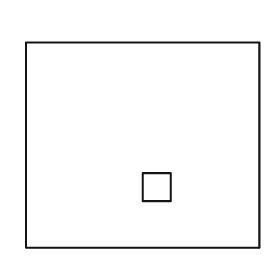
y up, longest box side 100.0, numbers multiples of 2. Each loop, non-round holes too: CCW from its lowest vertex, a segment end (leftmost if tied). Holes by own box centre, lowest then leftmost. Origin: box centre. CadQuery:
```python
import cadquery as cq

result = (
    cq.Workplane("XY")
    .moveTo(-50.0, -44.0)
    .lineTo(50.0, -44.0)
    .lineTo(50.0, 44.0)
    .lineTo(-50.0, 44.0)
    .close()
    .moveTo(0.0, -24.0)
    .lineTo(12.0, -24.0)
    .lineTo(12.0, -12.0)
    .lineTo(0.0, -12.0)
    .close()
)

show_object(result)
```